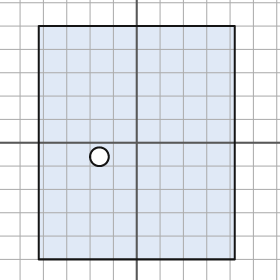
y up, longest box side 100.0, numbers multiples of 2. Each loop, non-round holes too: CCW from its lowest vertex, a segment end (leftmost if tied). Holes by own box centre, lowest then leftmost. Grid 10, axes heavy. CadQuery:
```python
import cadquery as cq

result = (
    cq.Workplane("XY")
    .moveTo(-42.0, -50.0)
    .lineTo(42.0, -50.0)
    .lineTo(42.0, 50.0)
    .lineTo(-42.0, 50.0)
    .close()
    .moveTo(-16.0, -6.0)
    .circle(4.0)
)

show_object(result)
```